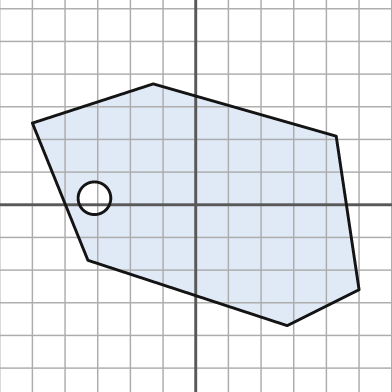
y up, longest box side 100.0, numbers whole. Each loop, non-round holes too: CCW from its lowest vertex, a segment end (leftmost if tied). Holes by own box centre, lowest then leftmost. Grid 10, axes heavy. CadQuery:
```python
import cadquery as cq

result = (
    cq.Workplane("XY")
    .moveTo(28.0, -37.0)
    .lineTo(50.0, -26.0)
    .lineTo(43.0, 21.0)
    .lineTo(-13.0, 37.0)
    .lineTo(-50.0, 25.0)
    .lineTo(-33.0, -17.0)
    .close()
    .moveTo(-31.0, 2.0)
    .circle(5.0)
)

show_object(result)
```